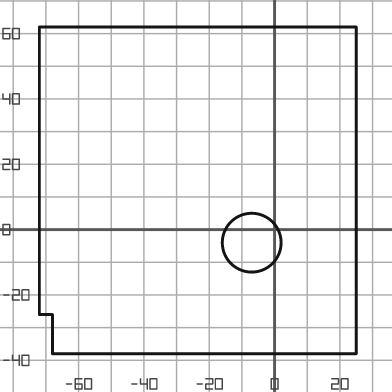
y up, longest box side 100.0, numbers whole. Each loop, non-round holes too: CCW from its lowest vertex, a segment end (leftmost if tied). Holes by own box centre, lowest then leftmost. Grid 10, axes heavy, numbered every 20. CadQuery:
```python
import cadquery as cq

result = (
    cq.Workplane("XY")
    .moveTo(-68.0, -38.0)
    .lineTo(25.0, -38.0)
    .lineTo(25.0, 62.0)
    .lineTo(-72.0, 62.0)
    .lineTo(-72.0, -26.0)
    .lineTo(-68.0, -26.0)
    .close()
    .moveTo(-7.0, -4.0)
    .circle(9.0)
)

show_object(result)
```